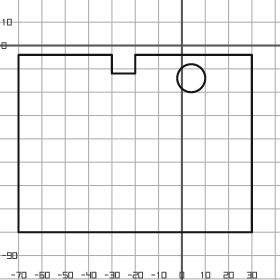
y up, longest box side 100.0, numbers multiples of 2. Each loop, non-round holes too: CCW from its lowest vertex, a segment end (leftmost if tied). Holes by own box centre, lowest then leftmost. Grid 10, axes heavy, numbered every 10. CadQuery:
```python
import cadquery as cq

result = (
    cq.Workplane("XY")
    .moveTo(-70.0, -80.0)
    .lineTo(30.0, -80.0)
    .lineTo(30.0, -4.0)
    .lineTo(-20.0, -4.0)
    .lineTo(-20.0, -12.0)
    .lineTo(-30.0, -12.0)
    .lineTo(-30.0, -4.0)
    .lineTo(-70.0, -4.0)
    .close()
    .moveTo(4.0, -14.0)
    .circle(6.0)
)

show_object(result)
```